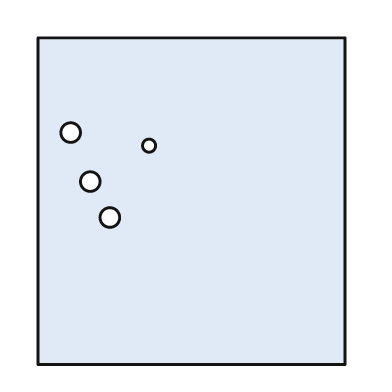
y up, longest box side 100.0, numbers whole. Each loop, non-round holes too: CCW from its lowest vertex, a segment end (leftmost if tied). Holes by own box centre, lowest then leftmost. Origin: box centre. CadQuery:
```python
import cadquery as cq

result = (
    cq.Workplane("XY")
    .moveTo(-47.0, -50.0)
    .lineTo(47.0, -50.0)
    .lineTo(47.0, 50.0)
    .lineTo(-47.0, 50.0)
    .close()
    .moveTo(-25.0, -5.0)
    .circle(3.0)
    .moveTo(-31.0, 6.0)
    .circle(3.0)
    .moveTo(-13.0, 17.0)
    .circle(2.0)
    .moveTo(-37.0, 21.0)
    .circle(3.0)
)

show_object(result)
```